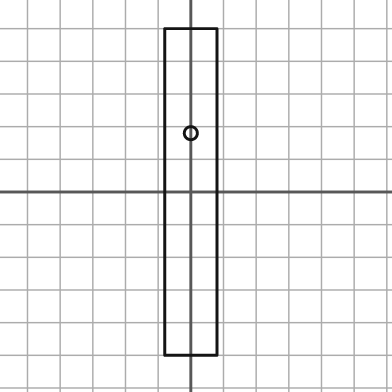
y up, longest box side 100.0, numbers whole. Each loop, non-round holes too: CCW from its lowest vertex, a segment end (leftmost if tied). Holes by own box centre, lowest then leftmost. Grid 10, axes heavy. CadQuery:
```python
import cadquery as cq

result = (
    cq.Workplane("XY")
    .moveTo(-8.0, -50.0)
    .lineTo(8.0, -50.0)
    .lineTo(8.0, 50.0)
    .lineTo(-8.0, 50.0)
    .close()
    .moveTo(0.0, 18.0)
    .circle(2.0)
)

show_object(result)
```